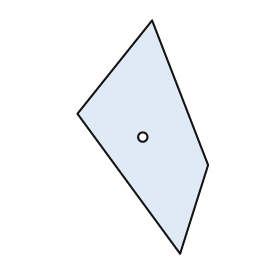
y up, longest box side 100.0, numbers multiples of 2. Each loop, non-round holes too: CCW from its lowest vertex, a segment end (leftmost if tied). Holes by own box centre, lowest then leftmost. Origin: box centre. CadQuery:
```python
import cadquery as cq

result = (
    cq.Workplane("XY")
    .moveTo(16.0, -50.0)
    .lineTo(28.0, -12.0)
    .lineTo(4.0, 50.0)
    .lineTo(-28.0, 10.0)
    .close()
    .moveTo(0.0, 0.0)
    .circle(2.0)
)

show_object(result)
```